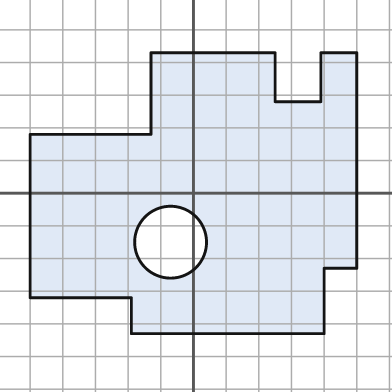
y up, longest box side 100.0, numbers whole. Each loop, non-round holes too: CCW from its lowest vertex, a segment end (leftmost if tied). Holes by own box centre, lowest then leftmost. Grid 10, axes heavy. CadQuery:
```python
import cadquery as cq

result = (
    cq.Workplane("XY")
    .moveTo(-19.0, -43.0)
    .lineTo(40.0, -43.0)
    .lineTo(40.0, -23.0)
    .lineTo(50.0, -23.0)
    .lineTo(50.0, 43.0)
    .lineTo(39.0, 43.0)
    .lineTo(39.0, 28.0)
    .lineTo(25.0, 28.0)
    .lineTo(25.0, 43.0)
    .lineTo(-13.0, 43.0)
    .lineTo(-13.0, 18.0)
    .lineTo(-50.0, 18.0)
    .lineTo(-50.0, -32.0)
    .lineTo(-19.0, -32.0)
    .close()
    .moveTo(-7.0, -15.0)
    .circle(11.0)
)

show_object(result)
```